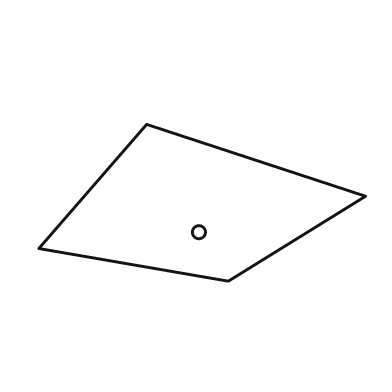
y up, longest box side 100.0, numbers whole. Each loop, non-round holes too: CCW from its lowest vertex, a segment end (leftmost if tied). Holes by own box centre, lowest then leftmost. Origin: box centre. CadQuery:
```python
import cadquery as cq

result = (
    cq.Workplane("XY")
    .moveTo(8.0, -24.0)
    .lineTo(50.0, 2.0)
    .lineTo(-17.0, 24.0)
    .lineTo(-50.0, -14.0)
    .close()
    .moveTo(-1.0, -9.0)
    .circle(2.0)
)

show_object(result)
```